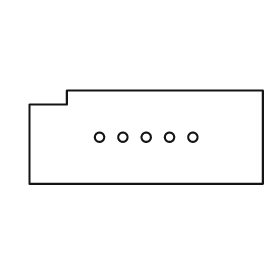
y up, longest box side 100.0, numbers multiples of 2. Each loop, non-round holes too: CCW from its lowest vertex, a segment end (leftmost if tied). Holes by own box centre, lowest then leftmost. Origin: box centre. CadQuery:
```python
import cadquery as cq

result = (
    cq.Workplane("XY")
    .moveTo(-50.0, -20.0)
    .lineTo(50.0, -20.0)
    .lineTo(50.0, 20.0)
    .lineTo(-34.0, 20.0)
    .lineTo(-34.0, 14.0)
    .lineTo(-50.0, 14.0)
    .close()
    .moveTo(-20.0, 0.0)
    .circle(2.0)
    .moveTo(-10.0, 0.0)
    .circle(2.0)
    .moveTo(0.0, 0.0)
    .circle(2.0)
    .moveTo(10.0, 0.0)
    .circle(2.0)
    .moveTo(20.0, 0.0)
    .circle(2.0)
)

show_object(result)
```